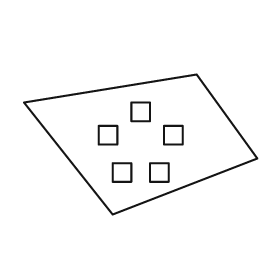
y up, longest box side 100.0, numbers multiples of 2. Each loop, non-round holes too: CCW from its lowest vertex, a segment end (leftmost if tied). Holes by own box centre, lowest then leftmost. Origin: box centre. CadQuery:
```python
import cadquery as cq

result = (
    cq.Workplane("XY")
    .moveTo(-12.0, -30.0)
    .lineTo(50.0, -6.0)
    .lineTo(24.0, 30.0)
    .lineTo(-50.0, 18.0)
    .close()
    .moveTo(-12.0, -16.0)
    .lineTo(-4.0, -16.0)
    .lineTo(-4.0, -8.0)
    .lineTo(-12.0, -8.0)
    .close()
    .moveTo(4.0, -16.0)
    .lineTo(12.0, -16.0)
    .lineTo(12.0, -8.0)
    .lineTo(4.0, -8.0)
    .close()
    .moveTo(-18.0, 0.0)
    .lineTo(-10.0, 0.0)
    .lineTo(-10.0, 8.0)
    .lineTo(-18.0, 8.0)
    .close()
    .moveTo(10.0, 0.0)
    .lineTo(18.0, 0.0)
    .lineTo(18.0, 8.0)
    .lineTo(10.0, 8.0)
    .close()
    .moveTo(-4.0, 10.0)
    .lineTo(4.0, 10.0)
    .lineTo(4.0, 18.0)
    .lineTo(-4.0, 18.0)
    .close()
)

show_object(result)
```